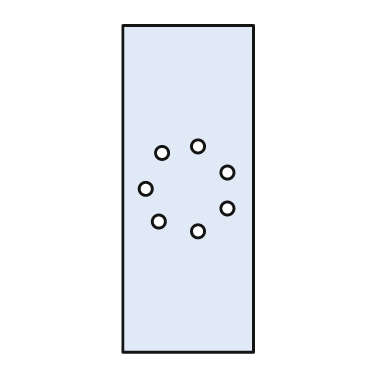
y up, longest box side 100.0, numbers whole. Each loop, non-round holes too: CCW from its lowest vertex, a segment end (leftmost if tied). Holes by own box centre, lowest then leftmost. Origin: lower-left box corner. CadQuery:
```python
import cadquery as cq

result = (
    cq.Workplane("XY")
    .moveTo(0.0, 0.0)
    .lineTo(40.0, 0.0)
    .lineTo(40.0, 100.0)
    .lineTo(0.0, 100.0)
    .close()
    .moveTo(23.0, 37.0)
    .circle(2.0)
    .moveTo(11.0, 40.0)
    .circle(2.0)
    .moveTo(32.0, 44.0)
    .circle(2.0)
    .moveTo(7.0, 50.0)
    .circle(2.0)
    .moveTo(32.0, 55.0)
    .circle(2.0)
    .moveTo(12.0, 61.0)
    .circle(2.0)
    .moveTo(23.0, 63.0)
    .circle(2.0)
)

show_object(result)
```